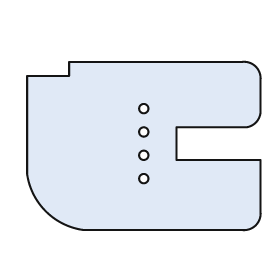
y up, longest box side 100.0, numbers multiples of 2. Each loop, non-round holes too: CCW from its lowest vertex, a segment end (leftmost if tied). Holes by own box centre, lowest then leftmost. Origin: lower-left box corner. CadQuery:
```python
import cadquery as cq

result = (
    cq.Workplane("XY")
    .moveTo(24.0, 0.0)
    .lineTo(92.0, 0.0)
    .threePointArc((98.0, 2.0), (100.0, 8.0))
    .lineTo(100.0, 30.0)
    .lineTo(64.0, 30.0)
    .lineTo(64.0, 44.0)
    .lineTo(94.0, 44.0)
    .threePointArc((98.0, 46.0), (100.0, 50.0))
    .lineTo(100.0, 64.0)
    .threePointArc((98.0, 70.0), (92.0, 72.0))
    .lineTo(18.0, 72.0)
    .lineTo(18.0, 66.0)
    .lineTo(0.0, 66.0)
    .lineTo(0.0, 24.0)
    .threePointArc((8.0, 8.0), (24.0, 0.0))
    .close()
    .moveTo(50.0, 22.0)
    .circle(2.0)
    .moveTo(50.0, 32.0)
    .circle(2.0)
    .moveTo(50.0, 42.0)
    .circle(2.0)
    .moveTo(50.0, 52.0)
    .circle(2.0)
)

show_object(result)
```